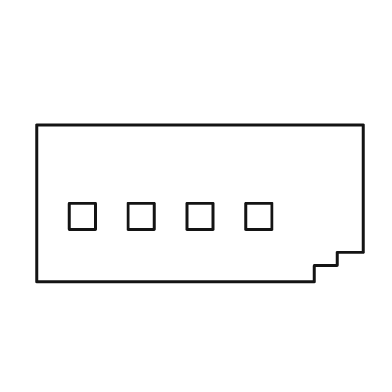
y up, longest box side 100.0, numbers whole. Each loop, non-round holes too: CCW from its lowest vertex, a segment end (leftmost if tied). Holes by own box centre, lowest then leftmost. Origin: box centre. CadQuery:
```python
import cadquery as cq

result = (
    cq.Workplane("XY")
    .moveTo(-50.0, -24.0)
    .lineTo(35.0, -24.0)
    .lineTo(35.0, -19.0)
    .lineTo(42.0, -19.0)
    .lineTo(42.0, -15.0)
    .lineTo(50.0, -15.0)
    .lineTo(50.0, 24.0)
    .lineTo(-50.0, 24.0)
    .close()
    .moveTo(-40.0, -8.0)
    .lineTo(-32.0, -8.0)
    .lineTo(-32.0, 0.0)
    .lineTo(-40.0, 0.0)
    .close()
    .moveTo(-22.0, -8.0)
    .lineTo(-14.0, -8.0)
    .lineTo(-14.0, 0.0)
    .lineTo(-22.0, 0.0)
    .close()
    .moveTo(-4.0, -8.0)
    .lineTo(4.0, -8.0)
    .lineTo(4.0, 0.0)
    .lineTo(-4.0, 0.0)
    .close()
    .moveTo(14.0, -8.0)
    .lineTo(22.0, -8.0)
    .lineTo(22.0, 0.0)
    .lineTo(14.0, 0.0)
    .close()
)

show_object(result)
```